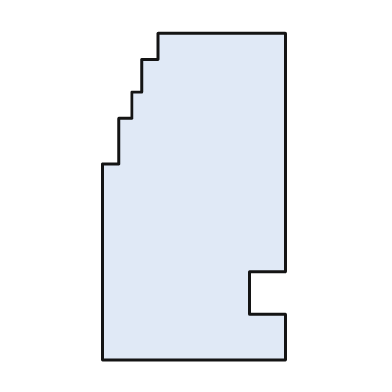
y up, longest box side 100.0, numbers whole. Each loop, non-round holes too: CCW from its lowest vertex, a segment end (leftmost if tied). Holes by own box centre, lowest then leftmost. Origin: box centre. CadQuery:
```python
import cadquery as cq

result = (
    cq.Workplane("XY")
    .moveTo(-28.0, -50.0)
    .lineTo(28.0, -50.0)
    .lineTo(28.0, -36.0)
    .lineTo(17.0, -36.0)
    .lineTo(17.0, -23.0)
    .lineTo(28.0, -23.0)
    .lineTo(28.0, 50.0)
    .lineTo(-11.0, 50.0)
    .lineTo(-11.0, 42.0)
    .lineTo(-16.0, 42.0)
    .lineTo(-16.0, 32.0)
    .lineTo(-19.0, 32.0)
    .lineTo(-19.0, 24.0)
    .lineTo(-23.0, 24.0)
    .lineTo(-23.0, 10.0)
    .lineTo(-28.0, 10.0)
    .close()
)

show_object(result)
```